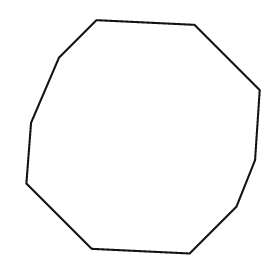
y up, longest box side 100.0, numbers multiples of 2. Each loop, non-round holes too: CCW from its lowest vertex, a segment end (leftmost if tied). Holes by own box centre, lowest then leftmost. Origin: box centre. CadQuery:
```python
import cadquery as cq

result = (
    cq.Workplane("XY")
    .moveTo(20.0, -50.0)
    .lineTo(40.0, -30.0)
    .lineTo(48.0, -10.0)
    .lineTo(50.0, 20.0)
    .lineTo(22.0, 48.0)
    .lineTo(-20.0, 50.0)
    .lineTo(-36.0, 34.0)
    .lineTo(-48.0, 6.0)
    .lineTo(-50.0, -20.0)
    .lineTo(-22.0, -48.0)
    .close()
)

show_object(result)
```